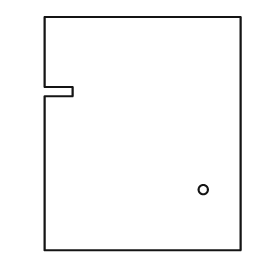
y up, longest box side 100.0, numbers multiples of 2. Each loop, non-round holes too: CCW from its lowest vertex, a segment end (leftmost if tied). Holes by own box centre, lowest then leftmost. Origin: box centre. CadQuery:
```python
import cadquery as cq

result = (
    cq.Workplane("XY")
    .moveTo(-42.0, -50.0)
    .lineTo(42.0, -50.0)
    .lineTo(42.0, 50.0)
    .lineTo(-42.0, 50.0)
    .lineTo(-42.0, 20.0)
    .lineTo(-30.0, 20.0)
    .lineTo(-30.0, 16.0)
    .lineTo(-42.0, 16.0)
    .close()
    .moveTo(26.0, -24.0)
    .circle(2.0)
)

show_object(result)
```